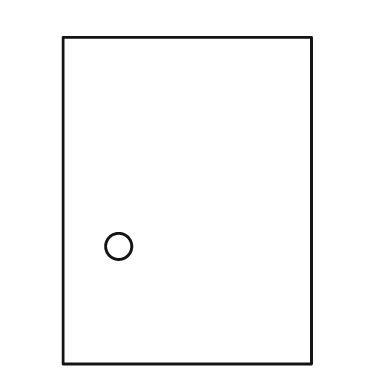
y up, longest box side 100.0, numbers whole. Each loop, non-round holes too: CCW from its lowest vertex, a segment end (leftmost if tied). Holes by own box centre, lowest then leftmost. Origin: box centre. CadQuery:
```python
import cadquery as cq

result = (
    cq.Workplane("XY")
    .moveTo(-38.0, -50.0)
    .lineTo(38.0, -50.0)
    .lineTo(38.0, 50.0)
    .lineTo(-38.0, 50.0)
    .close()
    .moveTo(-21.0, -14.0)
    .circle(4.0)
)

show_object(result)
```